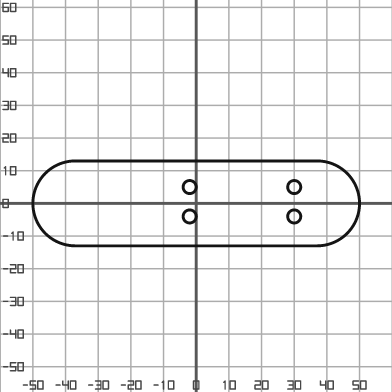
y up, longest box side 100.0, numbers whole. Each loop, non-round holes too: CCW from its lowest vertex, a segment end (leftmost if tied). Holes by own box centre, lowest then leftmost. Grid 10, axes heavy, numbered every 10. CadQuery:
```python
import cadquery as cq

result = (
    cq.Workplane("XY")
    .moveTo(-37.0, -13.0)
    .lineTo(37.0, -13.0)
    .threePointArc((50.0, 0.0), (37.0, 13.0))
    .lineTo(-37.0, 13.0)
    .threePointArc((-50.0, 0.0), (-37.0, -13.0))
    .close()
    .moveTo(-2.0, -4.0)
    .circle(2.0)
    .moveTo(30.0, -4.0)
    .circle(2.0)
    .moveTo(-2.0, 5.0)
    .circle(2.0)
    .moveTo(30.0, 5.0)
    .circle(2.0)
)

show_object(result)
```